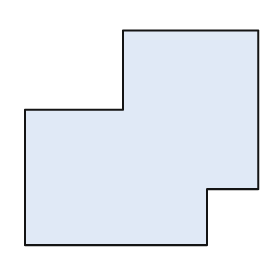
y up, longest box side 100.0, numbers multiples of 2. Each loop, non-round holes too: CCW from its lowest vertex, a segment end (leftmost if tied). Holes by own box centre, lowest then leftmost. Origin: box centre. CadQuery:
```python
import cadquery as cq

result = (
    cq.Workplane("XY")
    .moveTo(-50.0, -46.0)
    .lineTo(28.0, -46.0)
    .lineTo(28.0, -22.0)
    .lineTo(50.0, -22.0)
    .lineTo(50.0, 46.0)
    .lineTo(-8.0, 46.0)
    .lineTo(-8.0, 12.0)
    .lineTo(-50.0, 12.0)
    .close()
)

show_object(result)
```